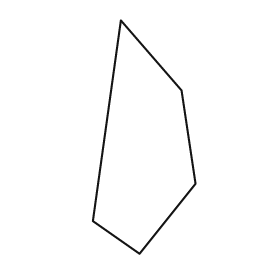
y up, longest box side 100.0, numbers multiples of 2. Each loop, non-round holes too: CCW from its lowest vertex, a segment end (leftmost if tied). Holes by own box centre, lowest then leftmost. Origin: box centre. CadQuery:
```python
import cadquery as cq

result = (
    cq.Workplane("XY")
    .moveTo(-2.0, -50.0)
    .lineTo(22.0, -20.0)
    .lineTo(16.0, 20.0)
    .lineTo(-10.0, 50.0)
    .lineTo(-22.0, -36.0)
    .close()
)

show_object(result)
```